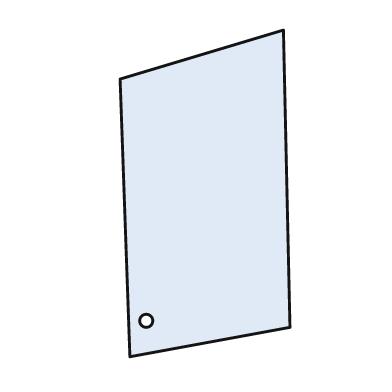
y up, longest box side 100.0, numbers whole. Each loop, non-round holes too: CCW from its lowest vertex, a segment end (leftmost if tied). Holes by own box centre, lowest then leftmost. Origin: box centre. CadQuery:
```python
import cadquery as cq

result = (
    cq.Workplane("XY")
    .moveTo(-23.0, -50.0)
    .lineTo(26.0, -41.0)
    .lineTo(24.0, 50.0)
    .lineTo(-26.0, 35.0)
    .close()
    .moveTo(-18.0, -39.0)
    .circle(2.0)
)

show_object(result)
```